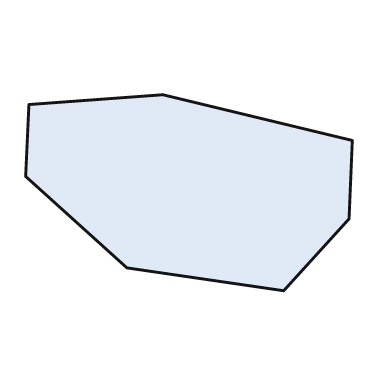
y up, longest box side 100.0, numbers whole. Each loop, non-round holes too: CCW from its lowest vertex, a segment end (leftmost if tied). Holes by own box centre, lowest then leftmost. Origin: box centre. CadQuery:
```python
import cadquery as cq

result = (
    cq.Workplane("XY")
    .moveTo(29.0, -30.0)
    .lineTo(49.0, -8.0)
    .lineTo(50.0, 16.0)
    .lineTo(-8.0, 30.0)
    .lineTo(-49.0, 27.0)
    .lineTo(-50.0, 5.0)
    .lineTo(-19.0, -23.0)
    .close()
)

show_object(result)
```